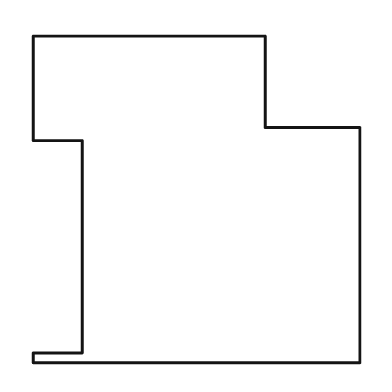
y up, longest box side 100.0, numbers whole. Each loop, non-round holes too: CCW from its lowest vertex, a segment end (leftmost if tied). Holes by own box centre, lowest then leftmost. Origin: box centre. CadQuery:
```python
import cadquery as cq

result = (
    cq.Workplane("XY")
    .moveTo(-50.0, -50.0)
    .lineTo(50.0, -50.0)
    .lineTo(50.0, 22.0)
    .lineTo(21.0, 22.0)
    .lineTo(21.0, 50.0)
    .lineTo(-50.0, 50.0)
    .lineTo(-50.0, 18.0)
    .lineTo(-35.0, 18.0)
    .lineTo(-35.0, -47.0)
    .lineTo(-50.0, -47.0)
    .close()
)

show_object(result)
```